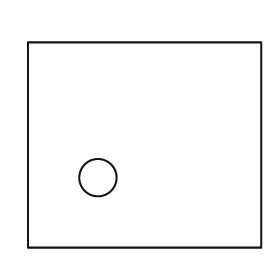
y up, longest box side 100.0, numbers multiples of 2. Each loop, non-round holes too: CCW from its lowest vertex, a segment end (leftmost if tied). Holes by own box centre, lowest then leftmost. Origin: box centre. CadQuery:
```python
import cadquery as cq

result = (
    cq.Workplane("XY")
    .moveTo(-50.0, -44.0)
    .lineTo(50.0, -44.0)
    .lineTo(50.0, 44.0)
    .lineTo(-50.0, 44.0)
    .close()
    .moveTo(-20.0, -14.0)
    .circle(8.0)
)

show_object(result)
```